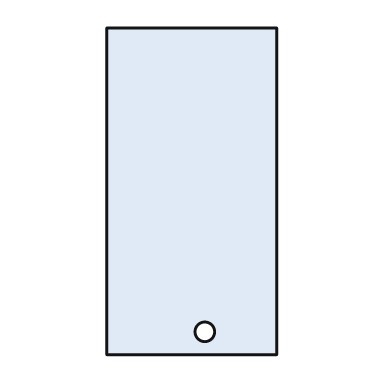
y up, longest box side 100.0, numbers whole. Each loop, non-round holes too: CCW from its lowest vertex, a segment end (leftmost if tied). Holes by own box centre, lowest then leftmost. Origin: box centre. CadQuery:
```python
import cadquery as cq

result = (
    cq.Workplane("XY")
    .moveTo(-26.0, -50.0)
    .lineTo(26.0, -50.0)
    .lineTo(26.0, 50.0)
    .lineTo(-26.0, 50.0)
    .close()
    .moveTo(4.0, -43.0)
    .circle(3.0)
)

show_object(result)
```